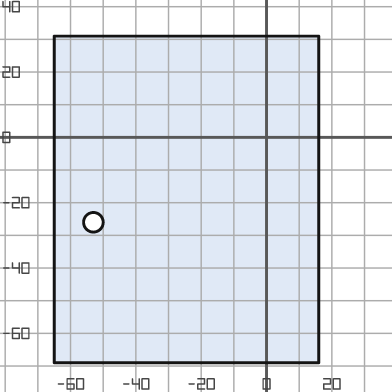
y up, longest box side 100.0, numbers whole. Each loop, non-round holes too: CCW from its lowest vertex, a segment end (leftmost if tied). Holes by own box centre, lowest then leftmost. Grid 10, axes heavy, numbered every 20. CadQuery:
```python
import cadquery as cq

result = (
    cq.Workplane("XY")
    .moveTo(-65.0, -69.0)
    .lineTo(16.0, -69.0)
    .lineTo(16.0, 31.0)
    .lineTo(-65.0, 31.0)
    .close()
    .moveTo(-53.0, -26.0)
    .circle(3.0)
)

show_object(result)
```